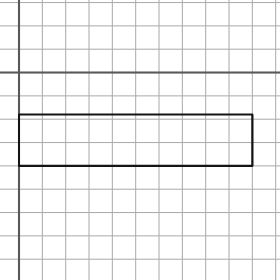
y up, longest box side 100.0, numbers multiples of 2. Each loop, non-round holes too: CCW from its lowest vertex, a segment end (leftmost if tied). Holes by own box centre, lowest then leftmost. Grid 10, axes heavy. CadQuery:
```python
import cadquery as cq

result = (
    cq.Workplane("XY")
    .moveTo(0.0, -40.0)
    .lineTo(100.0, -40.0)
    .lineTo(100.0, -18.0)
    .lineTo(0.0, -18.0)
    .close()
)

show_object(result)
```